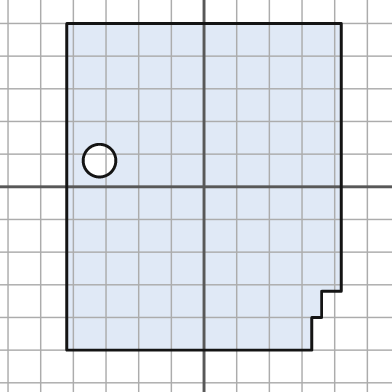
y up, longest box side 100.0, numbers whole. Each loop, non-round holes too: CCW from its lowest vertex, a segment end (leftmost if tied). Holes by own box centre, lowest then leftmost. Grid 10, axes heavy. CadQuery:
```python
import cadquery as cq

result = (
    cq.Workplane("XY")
    .moveTo(-42.0, -50.0)
    .lineTo(33.0, -50.0)
    .lineTo(33.0, -40.0)
    .lineTo(36.0, -40.0)
    .lineTo(36.0, -32.0)
    .lineTo(42.0, -32.0)
    .lineTo(42.0, 50.0)
    .lineTo(-42.0, 50.0)
    .close()
    .moveTo(-32.0, 8.0)
    .circle(5.0)
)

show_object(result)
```